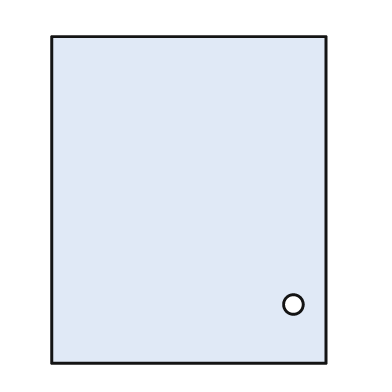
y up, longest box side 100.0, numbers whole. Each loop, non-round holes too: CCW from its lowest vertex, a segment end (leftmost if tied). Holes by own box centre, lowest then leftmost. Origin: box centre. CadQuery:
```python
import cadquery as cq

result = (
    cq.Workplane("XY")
    .moveTo(-42.0, -50.0)
    .lineTo(42.0, -50.0)
    .lineTo(42.0, 50.0)
    .lineTo(-42.0, 50.0)
    .close()
    .moveTo(32.0, -32.0)
    .circle(3.0)
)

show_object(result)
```